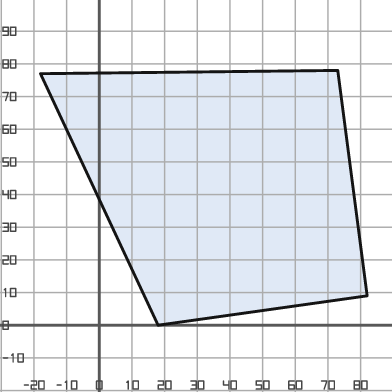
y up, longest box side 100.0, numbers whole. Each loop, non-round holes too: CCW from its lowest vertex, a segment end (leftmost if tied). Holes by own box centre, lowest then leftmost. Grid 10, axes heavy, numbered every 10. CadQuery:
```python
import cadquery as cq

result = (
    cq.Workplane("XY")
    .moveTo(18.0, 0.0)
    .lineTo(82.0, 9.0)
    .lineTo(73.0, 78.0)
    .lineTo(-18.0, 77.0)
    .close()
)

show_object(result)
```